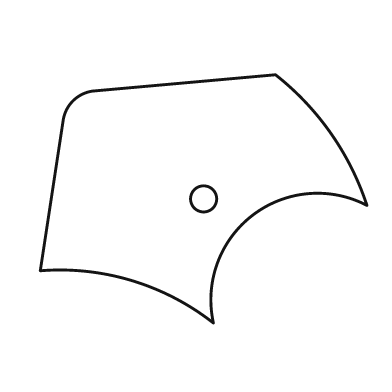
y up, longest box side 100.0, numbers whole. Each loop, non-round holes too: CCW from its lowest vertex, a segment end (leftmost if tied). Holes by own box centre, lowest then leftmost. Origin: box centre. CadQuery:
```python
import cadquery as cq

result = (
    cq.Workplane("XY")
    .moveTo(3.0, -38.0)
    .threePointArc((15.0, -5.0), (50.0, -2.0))
    .threePointArc((39.0, 20.0), (22.0, 38.0))
    .lineTo(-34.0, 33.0)
    .threePointArc((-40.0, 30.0), (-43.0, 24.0))
    .lineTo(-50.0, -22.0)
    .threePointArc((-22.0, -25.0), (3.0, -38.0))
    .close()
    .moveTo(0.0, 0.0)
    .circle(4.0)
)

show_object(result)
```